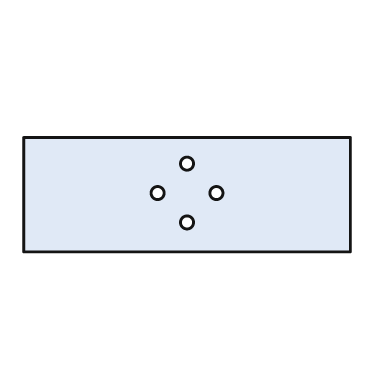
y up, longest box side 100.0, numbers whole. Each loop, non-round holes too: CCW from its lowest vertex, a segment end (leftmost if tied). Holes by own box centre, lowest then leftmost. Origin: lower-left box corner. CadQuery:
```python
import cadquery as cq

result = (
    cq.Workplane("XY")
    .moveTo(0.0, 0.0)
    .lineTo(100.0, 0.0)
    .lineTo(100.0, 35.0)
    .lineTo(0.0, 35.0)
    .close()
    .moveTo(50.0, 9.0)
    .circle(2.0)
    .moveTo(41.0, 18.0)
    .circle(2.0)
    .moveTo(59.0, 18.0)
    .circle(2.0)
    .moveTo(50.0, 27.0)
    .circle(2.0)
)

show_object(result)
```